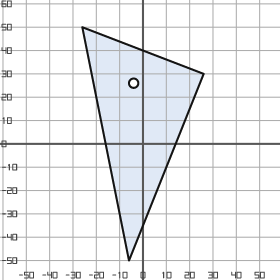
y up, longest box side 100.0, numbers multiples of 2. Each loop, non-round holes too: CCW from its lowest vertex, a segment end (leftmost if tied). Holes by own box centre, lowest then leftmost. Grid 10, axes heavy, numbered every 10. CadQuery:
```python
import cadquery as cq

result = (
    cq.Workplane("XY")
    .moveTo(-6.0, -50.0)
    .lineTo(26.0, 30.0)
    .lineTo(-26.0, 50.0)
    .close()
    .moveTo(-4.0, 26.0)
    .circle(2.0)
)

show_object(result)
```